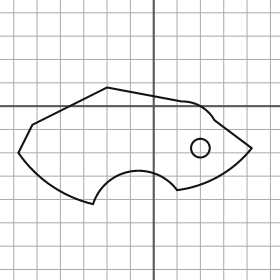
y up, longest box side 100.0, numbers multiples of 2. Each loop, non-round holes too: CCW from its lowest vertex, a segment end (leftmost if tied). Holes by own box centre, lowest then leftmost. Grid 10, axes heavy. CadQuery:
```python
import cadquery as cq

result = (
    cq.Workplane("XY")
    .moveTo(-26.0, -42.0)
    .threePointArc((-10.0, -28.0), (10.0, -36.0))
    .threePointArc((28.0, -30.0), (42.0, -18.0))
    .lineTo(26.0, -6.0)
    .threePointArc((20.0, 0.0), (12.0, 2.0))
    .lineTo(-20.0, 8.0)
    .lineTo(-52.0, -8.0)
    .lineTo(-58.0, -20.0)
    .threePointArc((-44.0, -34.0), (-26.0, -42.0))
    .close()
    .moveTo(20.0, -18.0)
    .circle(4.0)
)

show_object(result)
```